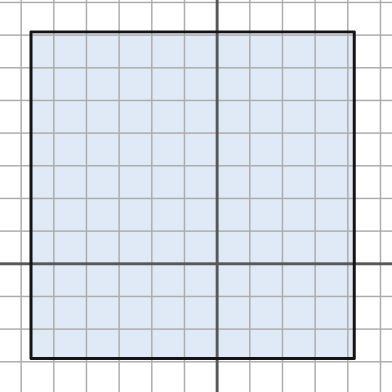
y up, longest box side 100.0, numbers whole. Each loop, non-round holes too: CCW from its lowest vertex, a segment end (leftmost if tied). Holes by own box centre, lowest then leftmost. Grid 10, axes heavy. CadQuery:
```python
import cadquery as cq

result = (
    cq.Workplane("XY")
    .moveTo(-57.0, -29.0)
    .lineTo(42.0, -29.0)
    .lineTo(42.0, 71.0)
    .lineTo(-57.0, 71.0)
    .close()
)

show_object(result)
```